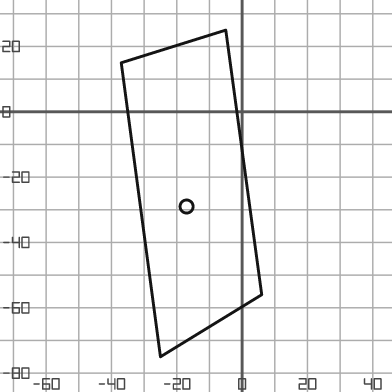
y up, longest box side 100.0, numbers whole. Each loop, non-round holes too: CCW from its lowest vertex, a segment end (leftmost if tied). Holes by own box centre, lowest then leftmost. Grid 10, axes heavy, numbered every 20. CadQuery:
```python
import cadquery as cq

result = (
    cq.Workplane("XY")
    .moveTo(-25.0, -75.0)
    .lineTo(6.0, -56.0)
    .lineTo(-5.0, 25.0)
    .lineTo(-37.0, 15.0)
    .close()
    .moveTo(-17.0, -29.0)
    .circle(2.0)
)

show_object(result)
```